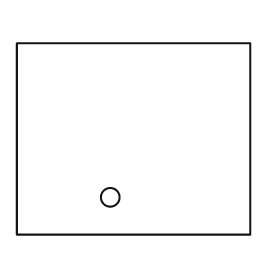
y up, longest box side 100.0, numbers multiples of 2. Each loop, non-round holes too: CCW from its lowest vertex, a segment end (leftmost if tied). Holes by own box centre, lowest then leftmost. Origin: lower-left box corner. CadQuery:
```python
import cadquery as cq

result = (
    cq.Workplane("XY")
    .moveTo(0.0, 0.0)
    .lineTo(100.0, 0.0)
    .lineTo(100.0, 82.0)
    .lineTo(0.0, 82.0)
    .close()
    .moveTo(40.0, 16.0)
    .circle(4.0)
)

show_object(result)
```